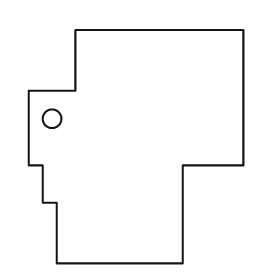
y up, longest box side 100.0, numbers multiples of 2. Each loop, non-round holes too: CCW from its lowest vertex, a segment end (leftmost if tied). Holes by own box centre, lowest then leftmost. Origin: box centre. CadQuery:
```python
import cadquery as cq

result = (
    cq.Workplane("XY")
    .moveTo(-34.0, -50.0)
    .lineTo(20.0, -50.0)
    .lineTo(20.0, -8.0)
    .lineTo(46.0, -8.0)
    .lineTo(46.0, 50.0)
    .lineTo(-26.0, 50.0)
    .lineTo(-26.0, 24.0)
    .lineTo(-46.0, 24.0)
    .lineTo(-46.0, -8.0)
    .lineTo(-40.0, -8.0)
    .lineTo(-40.0, -24.0)
    .lineTo(-34.0, -24.0)
    .close()
    .moveTo(-36.0, 12.0)
    .circle(4.0)
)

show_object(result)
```